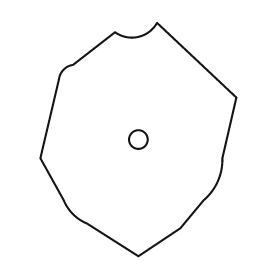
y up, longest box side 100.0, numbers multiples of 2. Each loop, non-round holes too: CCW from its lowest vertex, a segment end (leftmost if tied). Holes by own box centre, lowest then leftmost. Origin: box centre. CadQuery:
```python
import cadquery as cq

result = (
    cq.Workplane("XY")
    .moveTo(0.0, -50.0)
    .lineTo(18.0, -38.0)
    .lineTo(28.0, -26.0)
    .threePointArc((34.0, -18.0), (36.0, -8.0))
    .lineTo(42.0, 18.0)
    .lineTo(8.0, 50.0)
    .threePointArc((0.0, 44.0), (-10.0, 46.0))
    .lineTo(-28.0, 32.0)
    .threePointArc((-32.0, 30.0), (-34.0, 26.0))
    .lineTo(-42.0, -8.0)
    .lineTo(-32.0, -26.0)
    .threePointArc((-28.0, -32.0), (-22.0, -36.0))
    .close()
    .moveTo(0.0, 0.0)
    .circle(4.0)
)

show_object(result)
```